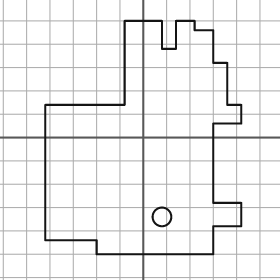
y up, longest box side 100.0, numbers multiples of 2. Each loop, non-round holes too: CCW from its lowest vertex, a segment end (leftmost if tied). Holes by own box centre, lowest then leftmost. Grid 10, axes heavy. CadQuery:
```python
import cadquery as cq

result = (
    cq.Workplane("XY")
    .moveTo(-20.0, -50.0)
    .lineTo(30.0, -50.0)
    .lineTo(30.0, -38.0)
    .lineTo(42.0, -38.0)
    .lineTo(42.0, -28.0)
    .lineTo(30.0, -28.0)
    .lineTo(30.0, 6.0)
    .lineTo(42.0, 6.0)
    .lineTo(42.0, 14.0)
    .lineTo(36.0, 14.0)
    .lineTo(36.0, 32.0)
    .lineTo(30.0, 32.0)
    .lineTo(30.0, 46.0)
    .lineTo(22.0, 46.0)
    .lineTo(22.0, 50.0)
    .lineTo(14.0, 50.0)
    .lineTo(14.0, 38.0)
    .lineTo(8.0, 38.0)
    .lineTo(8.0, 50.0)
    .lineTo(-8.0, 50.0)
    .lineTo(-8.0, 14.0)
    .lineTo(-42.0, 14.0)
    .lineTo(-42.0, -44.0)
    .lineTo(-20.0, -44.0)
    .close()
    .moveTo(8.0, -34.0)
    .circle(4.0)
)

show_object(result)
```